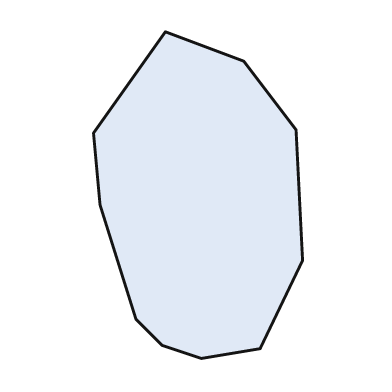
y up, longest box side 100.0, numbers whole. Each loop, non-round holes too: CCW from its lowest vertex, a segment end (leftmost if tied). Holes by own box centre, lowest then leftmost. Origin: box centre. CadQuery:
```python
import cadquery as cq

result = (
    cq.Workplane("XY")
    .moveTo(1.0, -50.0)
    .lineTo(19.0, -47.0)
    .lineTo(32.0, -20.0)
    .lineTo(30.0, 20.0)
    .lineTo(14.0, 41.0)
    .lineTo(-10.0, 50.0)
    .lineTo(-32.0, 19.0)
    .lineTo(-30.0, -3.0)
    .lineTo(-19.0, -38.0)
    .lineTo(-11.0, -46.0)
    .close()
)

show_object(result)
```